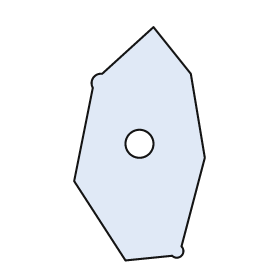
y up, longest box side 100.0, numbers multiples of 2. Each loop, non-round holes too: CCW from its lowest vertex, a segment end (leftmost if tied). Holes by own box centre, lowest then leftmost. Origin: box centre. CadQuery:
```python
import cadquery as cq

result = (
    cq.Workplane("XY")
    .moveTo(-6.0, -50.0)
    .lineTo(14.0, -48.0)
    .threePointArc((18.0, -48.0), (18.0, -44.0))
    .lineTo(28.0, -6.0)
    .lineTo(22.0, 30.0)
    .lineTo(6.0, 50.0)
    .lineTo(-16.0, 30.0)
    .threePointArc((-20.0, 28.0), (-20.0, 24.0))
    .lineTo(-28.0, -16.0)
    .close()
    .moveTo(0.0, 0.0)
    .circle(6.0)
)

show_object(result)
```